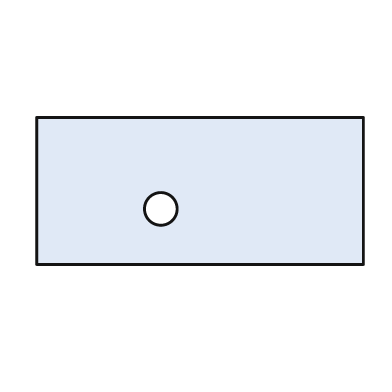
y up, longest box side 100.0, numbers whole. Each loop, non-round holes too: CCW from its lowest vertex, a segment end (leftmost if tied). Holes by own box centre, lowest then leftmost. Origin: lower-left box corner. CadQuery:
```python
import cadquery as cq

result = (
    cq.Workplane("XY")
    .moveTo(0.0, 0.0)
    .lineTo(100.0, 0.0)
    .lineTo(100.0, 45.0)
    .lineTo(0.0, 45.0)
    .close()
    .moveTo(38.0, 17.0)
    .circle(5.0)
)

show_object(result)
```